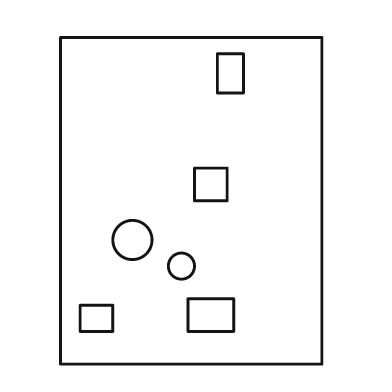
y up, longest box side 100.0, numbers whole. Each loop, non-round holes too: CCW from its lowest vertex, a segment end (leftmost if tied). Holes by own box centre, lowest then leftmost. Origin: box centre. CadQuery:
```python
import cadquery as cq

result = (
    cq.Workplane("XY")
    .moveTo(-40.0, -50.0)
    .lineTo(40.0, -50.0)
    .lineTo(40.0, 50.0)
    .lineTo(-40.0, 50.0)
    .close()
    .moveTo(-34.0, -40.0)
    .lineTo(-24.0, -40.0)
    .lineTo(-24.0, -32.0)
    .lineTo(-34.0, -32.0)
    .close()
    .moveTo(-1.0, -40.0)
    .lineTo(13.0, -40.0)
    .lineTo(13.0, -30.0)
    .lineTo(-1.0, -30.0)
    .close()
    .moveTo(-3.0, -20.0)
    .circle(4.0)
    .moveTo(-18.0, -12.0)
    .circle(6.0)
    .moveTo(1.0, 0.0)
    .lineTo(11.0, 0.0)
    .lineTo(11.0, 10.0)
    .lineTo(1.0, 10.0)
    .close()
    .moveTo(8.0, 33.0)
    .lineTo(16.0, 33.0)
    .lineTo(16.0, 45.0)
    .lineTo(8.0, 45.0)
    .close()
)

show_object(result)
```